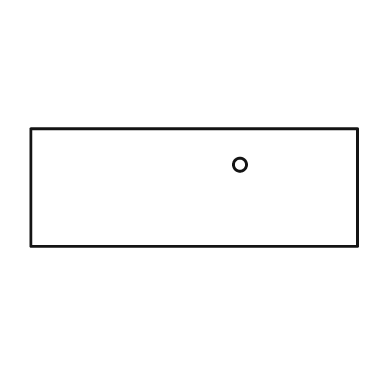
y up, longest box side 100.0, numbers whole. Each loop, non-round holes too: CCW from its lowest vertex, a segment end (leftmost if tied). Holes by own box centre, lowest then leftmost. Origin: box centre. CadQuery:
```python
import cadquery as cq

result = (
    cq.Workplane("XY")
    .moveTo(-50.0, -18.0)
    .lineTo(50.0, -18.0)
    .lineTo(50.0, 18.0)
    .lineTo(-50.0, 18.0)
    .close()
    .moveTo(14.0, 7.0)
    .circle(2.0)
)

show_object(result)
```